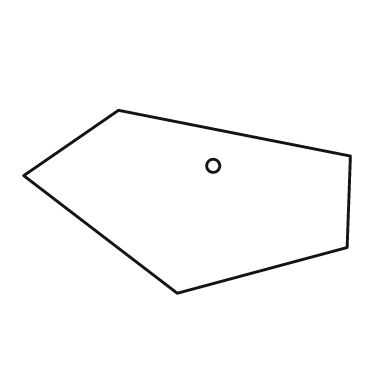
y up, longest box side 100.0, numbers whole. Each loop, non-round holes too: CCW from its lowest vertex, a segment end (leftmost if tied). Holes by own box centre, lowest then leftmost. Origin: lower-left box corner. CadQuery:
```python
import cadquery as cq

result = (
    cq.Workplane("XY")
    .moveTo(47.0, 0.0)
    .lineTo(99.0, 14.0)
    .lineTo(100.0, 42.0)
    .lineTo(29.0, 56.0)
    .lineTo(0.0, 36.0)
    .close()
    .moveTo(58.0, 39.0)
    .circle(2.0)
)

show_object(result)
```